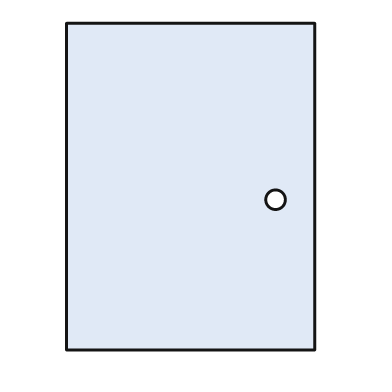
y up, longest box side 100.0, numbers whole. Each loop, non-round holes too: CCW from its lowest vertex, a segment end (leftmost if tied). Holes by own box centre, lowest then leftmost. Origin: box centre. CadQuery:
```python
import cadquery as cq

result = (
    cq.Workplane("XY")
    .moveTo(-38.0, -50.0)
    .lineTo(38.0, -50.0)
    .lineTo(38.0, 50.0)
    .lineTo(-38.0, 50.0)
    .close()
    .moveTo(26.0, -4.0)
    .circle(3.0)
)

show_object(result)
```